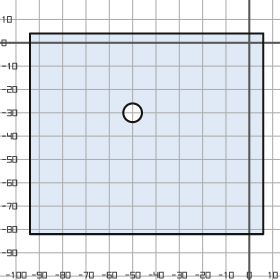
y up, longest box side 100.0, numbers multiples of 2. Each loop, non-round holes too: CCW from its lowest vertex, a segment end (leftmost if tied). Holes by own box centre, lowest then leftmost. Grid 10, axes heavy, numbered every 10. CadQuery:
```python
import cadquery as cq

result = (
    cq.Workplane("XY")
    .moveTo(-94.0, -82.0)
    .lineTo(6.0, -82.0)
    .lineTo(6.0, 4.0)
    .lineTo(-94.0, 4.0)
    .close()
    .moveTo(-50.0, -30.0)
    .circle(4.0)
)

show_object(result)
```